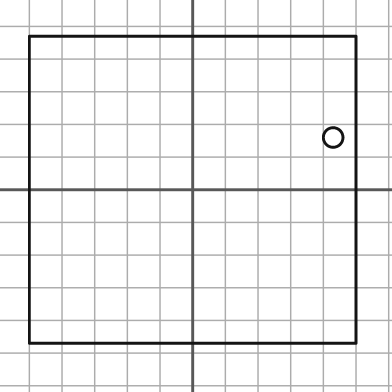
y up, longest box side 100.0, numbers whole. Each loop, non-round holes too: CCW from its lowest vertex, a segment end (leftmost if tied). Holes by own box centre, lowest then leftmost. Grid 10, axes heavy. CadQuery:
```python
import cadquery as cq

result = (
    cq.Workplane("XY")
    .moveTo(-50.0, -47.0)
    .lineTo(50.0, -47.0)
    .lineTo(50.0, 47.0)
    .lineTo(-50.0, 47.0)
    .close()
    .moveTo(43.0, 16.0)
    .circle(3.0)
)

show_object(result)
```